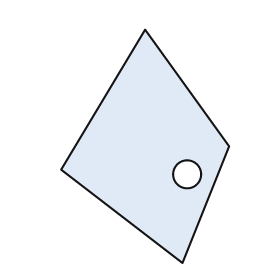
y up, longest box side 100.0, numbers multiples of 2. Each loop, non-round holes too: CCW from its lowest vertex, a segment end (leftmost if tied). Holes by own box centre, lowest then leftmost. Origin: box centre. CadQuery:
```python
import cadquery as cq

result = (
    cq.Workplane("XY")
    .moveTo(16.0, -50.0)
    .lineTo(36.0, 0.0)
    .lineTo(0.0, 50.0)
    .lineTo(-36.0, -10.0)
    .close()
    .moveTo(18.0, -12.0)
    .circle(6.0)
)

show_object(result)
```